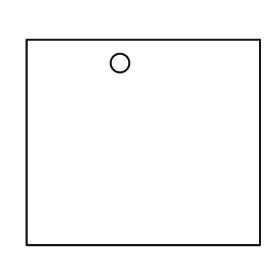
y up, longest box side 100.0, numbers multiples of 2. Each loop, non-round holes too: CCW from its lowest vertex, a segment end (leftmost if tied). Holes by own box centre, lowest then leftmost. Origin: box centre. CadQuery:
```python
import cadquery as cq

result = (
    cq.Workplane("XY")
    .moveTo(-50.0, -44.0)
    .lineTo(50.0, -44.0)
    .lineTo(50.0, 44.0)
    .lineTo(-50.0, 44.0)
    .close()
    .moveTo(-10.0, 34.0)
    .circle(4.0)
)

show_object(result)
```